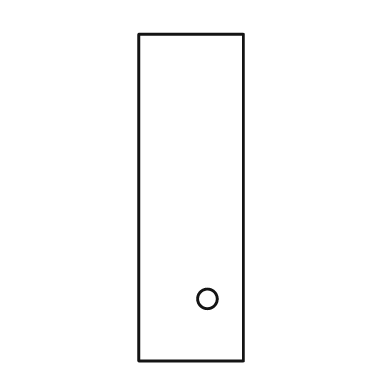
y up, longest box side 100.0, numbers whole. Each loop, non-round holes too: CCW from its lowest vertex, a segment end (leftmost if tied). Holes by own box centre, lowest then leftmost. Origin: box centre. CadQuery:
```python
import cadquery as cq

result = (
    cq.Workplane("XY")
    .moveTo(-16.0, -50.0)
    .lineTo(16.0, -50.0)
    .lineTo(16.0, 50.0)
    .lineTo(-16.0, 50.0)
    .close()
    .moveTo(5.0, -31.0)
    .circle(3.0)
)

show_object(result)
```